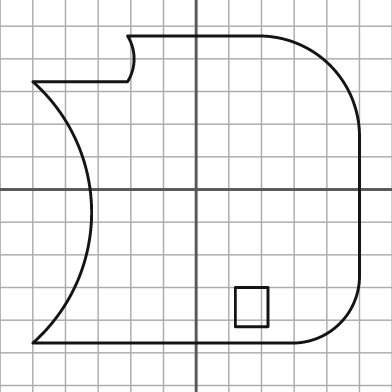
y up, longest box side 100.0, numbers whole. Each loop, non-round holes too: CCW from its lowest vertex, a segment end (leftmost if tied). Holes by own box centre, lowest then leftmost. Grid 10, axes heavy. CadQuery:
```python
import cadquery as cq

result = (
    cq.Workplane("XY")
    .moveTo(-50.0, -47.0)
    .lineTo(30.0, -47.0)
    .threePointArc((44.0, -41.0), (50.0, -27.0))
    .lineTo(50.0, 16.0)
    .threePointArc((41.0, 38.0), (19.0, 47.0))
    .lineTo(-21.0, 47.0)
    .threePointArc((-19.0, 40.0), (-21.0, 33.0))
    .lineTo(-50.0, 33.0)
    .threePointArc((-32.0, -7.0), (-50.0, -47.0))
    .close()
    .moveTo(12.0, -42.0)
    .lineTo(22.0, -42.0)
    .lineTo(22.0, -30.0)
    .lineTo(12.0, -30.0)
    .close()
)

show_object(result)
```